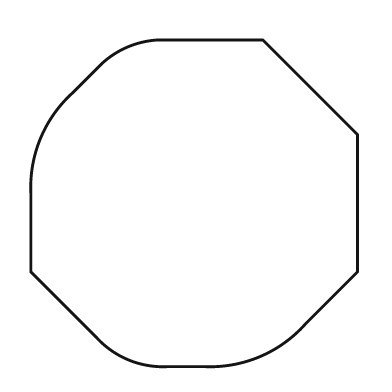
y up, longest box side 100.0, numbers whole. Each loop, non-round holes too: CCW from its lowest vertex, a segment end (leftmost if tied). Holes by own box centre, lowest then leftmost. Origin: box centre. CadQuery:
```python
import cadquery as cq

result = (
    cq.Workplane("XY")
    .moveTo(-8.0, -50.0)
    .lineTo(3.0, -50.0)
    .threePointArc((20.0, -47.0), (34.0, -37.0))
    .lineTo(50.0, -21.0)
    .lineTo(50.0, 21.0)
    .lineTo(21.0, 50.0)
    .lineTo(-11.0, 50.0)
    .threePointArc((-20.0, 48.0), (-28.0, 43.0))
    .lineTo(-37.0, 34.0)
    .threePointArc((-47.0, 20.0), (-50.0, 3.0))
    .lineTo(-50.0, -21.0)
    .lineTo(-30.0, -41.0)
    .threePointArc((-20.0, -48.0), (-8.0, -50.0))
    .close()
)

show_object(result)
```